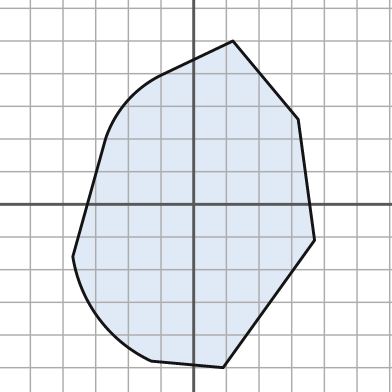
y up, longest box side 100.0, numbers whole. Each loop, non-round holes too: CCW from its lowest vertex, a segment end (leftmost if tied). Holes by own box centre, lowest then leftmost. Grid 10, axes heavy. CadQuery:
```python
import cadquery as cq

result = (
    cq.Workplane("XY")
    .moveTo(9.0, -50.0)
    .lineTo(37.0, -11.0)
    .lineTo(32.0, 26.0)
    .lineTo(12.0, 50.0)
    .lineTo(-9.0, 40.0)
    .threePointArc((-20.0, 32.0), (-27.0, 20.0))
    .lineTo(-37.0, -16.0)
    .threePointArc((-29.0, -35.0), (-13.0, -48.0))
    .close()
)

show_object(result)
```